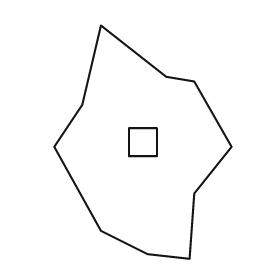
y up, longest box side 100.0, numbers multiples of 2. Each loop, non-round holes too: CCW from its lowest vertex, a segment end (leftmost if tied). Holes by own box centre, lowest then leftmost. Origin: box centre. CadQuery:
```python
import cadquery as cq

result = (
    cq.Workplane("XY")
    .moveTo(20.0, -50.0)
    .lineTo(22.0, -22.0)
    .lineTo(38.0, -2.0)
    .lineTo(22.0, 26.0)
    .lineTo(10.0, 28.0)
    .lineTo(-18.0, 50.0)
    .lineTo(-26.0, 16.0)
    .lineTo(-38.0, -2.0)
    .lineTo(-18.0, -38.0)
    .lineTo(2.0, -48.0)
    .close()
    .moveTo(-6.0, -6.0)
    .lineTo(6.0, -6.0)
    .lineTo(6.0, 6.0)
    .lineTo(-6.0, 6.0)
    .close()
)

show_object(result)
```